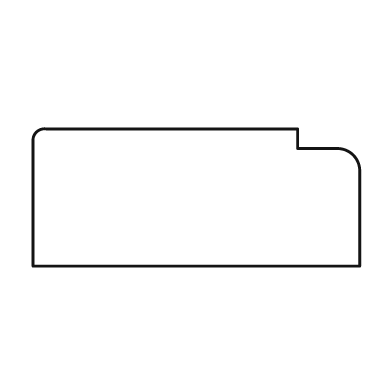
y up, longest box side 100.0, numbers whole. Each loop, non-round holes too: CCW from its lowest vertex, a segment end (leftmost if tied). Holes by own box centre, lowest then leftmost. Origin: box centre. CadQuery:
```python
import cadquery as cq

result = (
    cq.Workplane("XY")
    .moveTo(-50.0, -21.0)
    .lineTo(50.0, -21.0)
    .lineTo(50.0, 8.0)
    .threePointArc((48.0, 13.0), (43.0, 15.0))
    .lineTo(31.0, 15.0)
    .lineTo(31.0, 21.0)
    .lineTo(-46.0, 21.0)
    .threePointArc((-49.0, 20.0), (-50.0, 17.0))
    .close()
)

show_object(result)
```